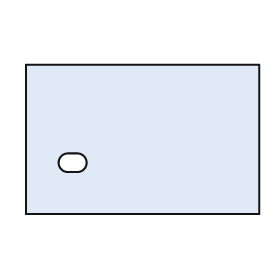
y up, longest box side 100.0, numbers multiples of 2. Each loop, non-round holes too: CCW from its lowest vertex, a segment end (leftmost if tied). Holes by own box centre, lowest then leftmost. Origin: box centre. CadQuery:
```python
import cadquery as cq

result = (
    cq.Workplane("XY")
    .moveTo(-50.0, -32.0)
    .lineTo(50.0, -32.0)
    .lineTo(50.0, 32.0)
    .lineTo(-50.0, 32.0)
    .close()
    .moveTo(-32.0, -14.0)
    .lineTo(-28.0, -14.0)
    .threePointArc((-24.0, -10.0), (-28.0, -6.0))
    .lineTo(-32.0, -6.0)
    .threePointArc((-36.0, -10.0), (-32.0, -14.0))
    .close()
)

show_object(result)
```